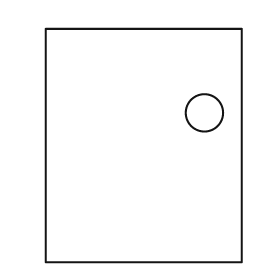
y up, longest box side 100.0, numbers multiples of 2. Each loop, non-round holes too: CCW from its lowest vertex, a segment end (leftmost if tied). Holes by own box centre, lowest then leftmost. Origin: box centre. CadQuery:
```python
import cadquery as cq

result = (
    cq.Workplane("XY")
    .moveTo(-42.0, -50.0)
    .lineTo(42.0, -50.0)
    .lineTo(42.0, 50.0)
    .lineTo(-42.0, 50.0)
    .close()
    .moveTo(26.0, 14.0)
    .circle(8.0)
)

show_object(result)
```